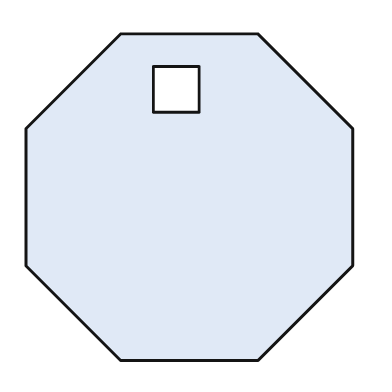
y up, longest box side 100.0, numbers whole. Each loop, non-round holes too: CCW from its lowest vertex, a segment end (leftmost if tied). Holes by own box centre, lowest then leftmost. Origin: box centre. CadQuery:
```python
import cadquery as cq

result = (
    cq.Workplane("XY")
    .moveTo(-21.0, -50.0)
    .lineTo(21.0, -50.0)
    .lineTo(50.0, -21.0)
    .lineTo(50.0, 21.0)
    .lineTo(21.0, 50.0)
    .lineTo(-21.0, 50.0)
    .lineTo(-50.0, 21.0)
    .lineTo(-50.0, -21.0)
    .close()
    .moveTo(-11.0, 26.0)
    .lineTo(3.0, 26.0)
    .lineTo(3.0, 40.0)
    .lineTo(-11.0, 40.0)
    .close()
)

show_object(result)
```